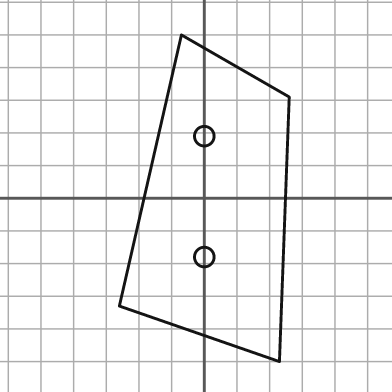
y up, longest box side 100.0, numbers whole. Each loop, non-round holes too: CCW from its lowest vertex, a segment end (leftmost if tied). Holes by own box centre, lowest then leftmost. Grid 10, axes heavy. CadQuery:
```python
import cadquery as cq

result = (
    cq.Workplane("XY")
    .moveTo(23.0, -50.0)
    .lineTo(26.0, 31.0)
    .lineTo(-7.0, 50.0)
    .lineTo(-26.0, -33.0)
    .close()
    .moveTo(0.0, -18.0)
    .circle(3.0)
    .moveTo(0.0, 19.0)
    .circle(3.0)
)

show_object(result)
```